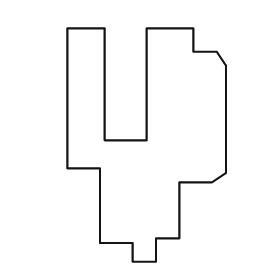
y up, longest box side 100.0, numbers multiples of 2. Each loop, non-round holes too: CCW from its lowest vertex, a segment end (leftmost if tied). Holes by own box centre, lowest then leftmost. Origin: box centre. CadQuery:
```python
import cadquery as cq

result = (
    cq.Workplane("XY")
    .moveTo(-6.0, -50.0)
    .lineTo(4.0, -50.0)
    .lineTo(4.0, -40.0)
    .lineTo(14.0, -40.0)
    .lineTo(14.0, -16.0)
    .lineTo(28.0, -16.0)
    .lineTo(34.0, -12.0)
    .lineTo(34.0, 34.0)
    .lineTo(30.0, 40.0)
    .lineTo(20.0, 40.0)
    .lineTo(20.0, 50.0)
    .lineTo(0.0, 50.0)
    .lineTo(0.0, 2.0)
    .lineTo(-18.0, 2.0)
    .lineTo(-18.0, 50.0)
    .lineTo(-34.0, 50.0)
    .lineTo(-34.0, -10.0)
    .lineTo(-20.0, -10.0)
    .lineTo(-20.0, -42.0)
    .lineTo(-6.0, -42.0)
    .close()
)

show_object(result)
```